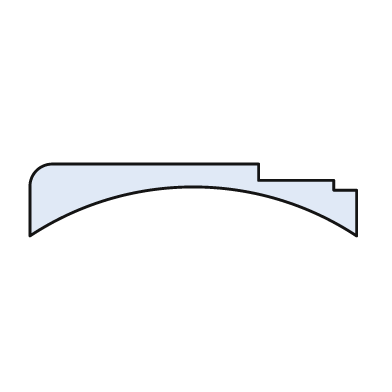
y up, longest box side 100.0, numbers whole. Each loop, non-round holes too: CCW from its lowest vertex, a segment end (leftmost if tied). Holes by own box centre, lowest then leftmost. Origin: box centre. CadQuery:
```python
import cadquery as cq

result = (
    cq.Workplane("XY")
    .moveTo(-50.0, -11.0)
    .threePointArc((0.0, 4.0), (50.0, -11.0))
    .lineTo(50.0, 3.0)
    .lineTo(43.0, 3.0)
    .lineTo(43.0, 6.0)
    .lineTo(20.0, 6.0)
    .lineTo(20.0, 11.0)
    .lineTo(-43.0, 11.0)
    .threePointArc((-48.0, 9.0), (-50.0, 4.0))
    .close()
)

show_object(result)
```